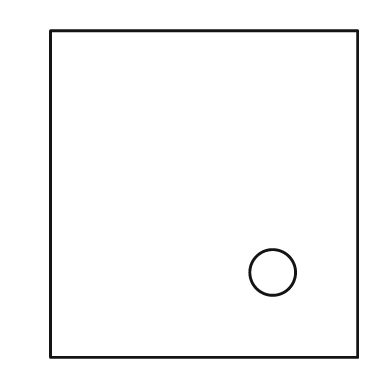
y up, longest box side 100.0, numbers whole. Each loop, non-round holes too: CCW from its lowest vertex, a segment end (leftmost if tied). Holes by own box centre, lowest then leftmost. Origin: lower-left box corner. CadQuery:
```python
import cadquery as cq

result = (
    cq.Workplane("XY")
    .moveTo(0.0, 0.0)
    .lineTo(94.0, 0.0)
    .lineTo(94.0, 100.0)
    .lineTo(0.0, 100.0)
    .close()
    .moveTo(68.0, 26.0)
    .circle(7.0)
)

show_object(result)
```